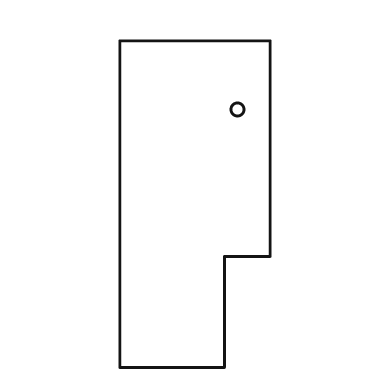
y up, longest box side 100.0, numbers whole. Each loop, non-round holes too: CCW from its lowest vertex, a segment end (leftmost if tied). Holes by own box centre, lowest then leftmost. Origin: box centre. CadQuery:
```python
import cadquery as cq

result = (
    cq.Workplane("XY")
    .moveTo(-23.0, -50.0)
    .lineTo(9.0, -50.0)
    .lineTo(9.0, -16.0)
    .lineTo(23.0, -16.0)
    .lineTo(23.0, 50.0)
    .lineTo(-23.0, 50.0)
    .close()
    .moveTo(13.0, 29.0)
    .circle(2.0)
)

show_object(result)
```